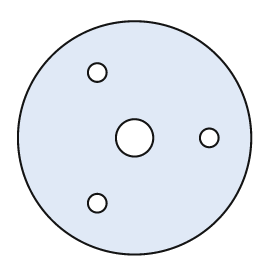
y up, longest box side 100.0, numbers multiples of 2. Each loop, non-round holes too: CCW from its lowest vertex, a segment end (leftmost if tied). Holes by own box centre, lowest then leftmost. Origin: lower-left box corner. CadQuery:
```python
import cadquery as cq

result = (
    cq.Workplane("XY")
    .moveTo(50.0, 50.0)
    .circle(50.0)
    .moveTo(34.0, 22.0)
    .circle(4.0)
    .moveTo(50.0, 50.0)
    .circle(8.0)
    .moveTo(82.0, 50.0)
    .circle(4.0)
    .moveTo(34.0, 78.0)
    .circle(4.0)
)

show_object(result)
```